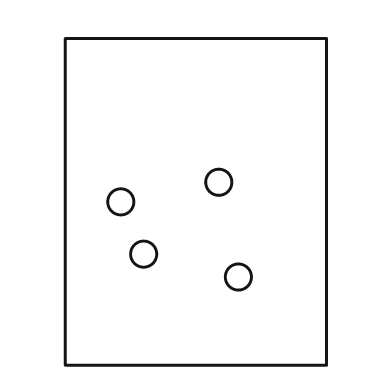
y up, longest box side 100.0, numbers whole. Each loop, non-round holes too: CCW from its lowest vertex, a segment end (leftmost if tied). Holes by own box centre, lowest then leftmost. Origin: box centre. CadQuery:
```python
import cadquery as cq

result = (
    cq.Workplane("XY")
    .moveTo(-40.0, -50.0)
    .lineTo(40.0, -50.0)
    .lineTo(40.0, 50.0)
    .lineTo(-40.0, 50.0)
    .close()
    .moveTo(13.0, -23.0)
    .circle(4.0)
    .moveTo(-16.0, -16.0)
    .circle(4.0)
    .moveTo(-23.0, 0.0)
    .circle(4.0)
    .moveTo(7.0, 6.0)
    .circle(4.0)
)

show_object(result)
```